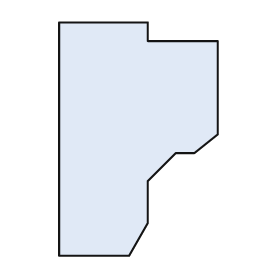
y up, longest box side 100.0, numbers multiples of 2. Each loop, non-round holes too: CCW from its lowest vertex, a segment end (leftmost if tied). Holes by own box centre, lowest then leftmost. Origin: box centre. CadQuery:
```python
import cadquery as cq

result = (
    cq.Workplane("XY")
    .moveTo(-34.0, -50.0)
    .lineTo(-4.0, -50.0)
    .lineTo(4.0, -36.0)
    .lineTo(4.0, -18.0)
    .lineTo(16.0, -6.0)
    .lineTo(24.0, -6.0)
    .lineTo(34.0, 2.0)
    .lineTo(34.0, 42.0)
    .lineTo(4.0, 42.0)
    .lineTo(4.0, 50.0)
    .lineTo(-34.0, 50.0)
    .close()
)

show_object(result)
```